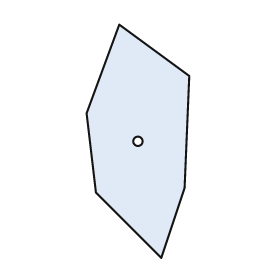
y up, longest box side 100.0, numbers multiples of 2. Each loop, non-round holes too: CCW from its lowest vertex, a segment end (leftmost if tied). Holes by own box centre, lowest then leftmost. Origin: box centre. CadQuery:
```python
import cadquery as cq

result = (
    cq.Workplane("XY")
    .moveTo(10.0, -50.0)
    .lineTo(20.0, -20.0)
    .lineTo(22.0, 28.0)
    .lineTo(-8.0, 50.0)
    .lineTo(-22.0, 12.0)
    .lineTo(-18.0, -22.0)
    .close()
    .moveTo(0.0, 0.0)
    .circle(2.0)
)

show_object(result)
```